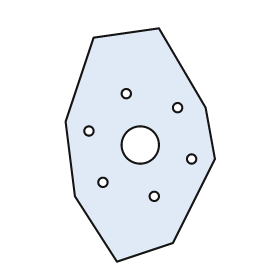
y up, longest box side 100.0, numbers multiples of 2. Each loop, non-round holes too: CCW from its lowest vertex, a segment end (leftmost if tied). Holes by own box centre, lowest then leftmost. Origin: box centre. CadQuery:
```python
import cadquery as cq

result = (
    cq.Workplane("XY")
    .moveTo(-10.0, -50.0)
    .lineTo(14.0, -42.0)
    .lineTo(32.0, -6.0)
    .lineTo(28.0, 16.0)
    .lineTo(8.0, 50.0)
    .lineTo(-20.0, 46.0)
    .lineTo(-32.0, 10.0)
    .lineTo(-28.0, -22.0)
    .close()
    .moveTo(6.0, -22.0)
    .circle(2.0)
    .moveTo(-16.0, -16.0)
    .circle(2.0)
    .moveTo(22.0, -6.0)
    .circle(2.0)
    .moveTo(0.0, 0.0)
    .circle(8.0)
    .moveTo(-22.0, 6.0)
    .circle(2.0)
    .moveTo(16.0, 16.0)
    .circle(2.0)
    .moveTo(-6.0, 22.0)
    .circle(2.0)
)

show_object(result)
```